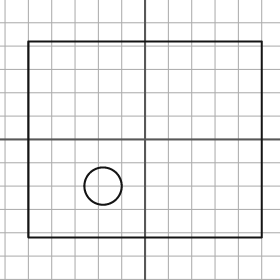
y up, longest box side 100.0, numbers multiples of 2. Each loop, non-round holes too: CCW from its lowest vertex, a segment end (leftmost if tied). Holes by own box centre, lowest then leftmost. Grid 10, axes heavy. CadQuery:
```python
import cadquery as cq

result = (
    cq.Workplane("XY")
    .moveTo(-50.0, -42.0)
    .lineTo(50.0, -42.0)
    .lineTo(50.0, 42.0)
    .lineTo(-50.0, 42.0)
    .close()
    .moveTo(-18.0, -20.0)
    .circle(8.0)
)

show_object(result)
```